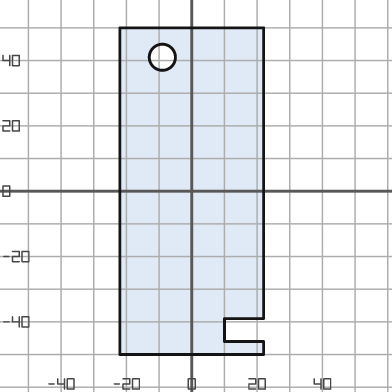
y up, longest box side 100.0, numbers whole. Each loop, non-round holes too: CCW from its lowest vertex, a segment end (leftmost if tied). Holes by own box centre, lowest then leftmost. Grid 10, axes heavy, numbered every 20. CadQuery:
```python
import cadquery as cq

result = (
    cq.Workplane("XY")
    .moveTo(-22.0, -50.0)
    .lineTo(22.0, -50.0)
    .lineTo(22.0, -46.0)
    .lineTo(10.0, -46.0)
    .lineTo(10.0, -39.0)
    .lineTo(22.0, -39.0)
    .lineTo(22.0, 50.0)
    .lineTo(-22.0, 50.0)
    .close()
    .moveTo(-9.0, 41.0)
    .circle(4.0)
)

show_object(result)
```